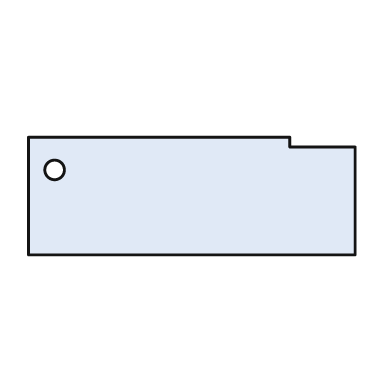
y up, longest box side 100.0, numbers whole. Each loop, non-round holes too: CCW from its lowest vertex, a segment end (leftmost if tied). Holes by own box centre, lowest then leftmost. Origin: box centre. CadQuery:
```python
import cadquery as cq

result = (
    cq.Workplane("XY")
    .moveTo(-50.0, -18.0)
    .lineTo(50.0, -18.0)
    .lineTo(50.0, 15.0)
    .lineTo(30.0, 15.0)
    .lineTo(30.0, 18.0)
    .lineTo(-50.0, 18.0)
    .close()
    .moveTo(-42.0, 8.0)
    .circle(3.0)
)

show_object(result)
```